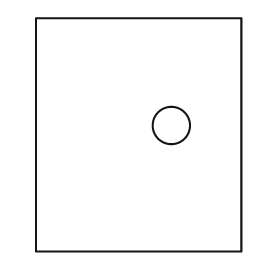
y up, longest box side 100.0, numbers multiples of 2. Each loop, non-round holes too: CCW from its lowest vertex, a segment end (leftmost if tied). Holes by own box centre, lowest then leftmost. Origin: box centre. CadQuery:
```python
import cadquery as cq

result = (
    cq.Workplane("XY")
    .moveTo(-44.0, -50.0)
    .lineTo(44.0, -50.0)
    .lineTo(44.0, 50.0)
    .lineTo(-44.0, 50.0)
    .close()
    .moveTo(14.0, 4.0)
    .circle(8.0)
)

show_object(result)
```